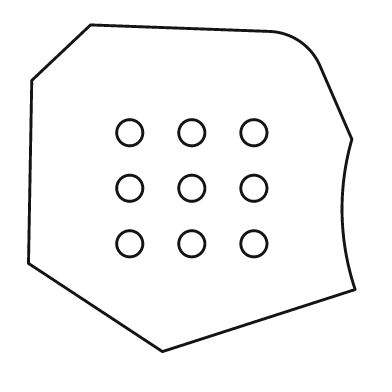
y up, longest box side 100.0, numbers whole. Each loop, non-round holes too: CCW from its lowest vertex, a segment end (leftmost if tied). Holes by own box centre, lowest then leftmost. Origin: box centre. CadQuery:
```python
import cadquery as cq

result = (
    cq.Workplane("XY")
    .moveTo(-9.0, -50.0)
    .lineTo(50.0, -31.0)
    .threePointArc((46.0, -8.0), (49.0, 15.0))
    .lineTo(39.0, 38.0)
    .threePointArc((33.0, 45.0), (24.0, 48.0))
    .lineTo(-31.0, 50.0)
    .lineTo(-49.0, 33.0)
    .lineTo(-50.0, -23.0)
    .close()
    .moveTo(-19.0, -17.0)
    .circle(4.0)
    .moveTo(0.0, -17.0)
    .circle(4.0)
    .moveTo(19.0, -17.0)
    .circle(4.0)
    .moveTo(-19.0, 0.0)
    .circle(4.0)
    .moveTo(0.0, 0.0)
    .circle(4.0)
    .moveTo(19.0, 0.0)
    .circle(4.0)
    .moveTo(-19.0, 17.0)
    .circle(4.0)
    .moveTo(0.0, 17.0)
    .circle(4.0)
    .moveTo(19.0, 17.0)
    .circle(4.0)
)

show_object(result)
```